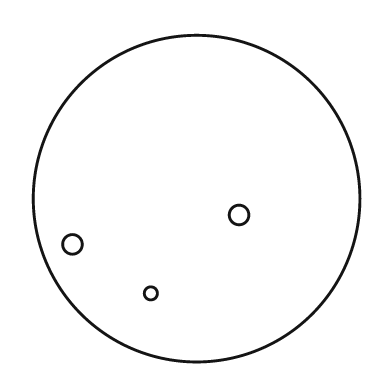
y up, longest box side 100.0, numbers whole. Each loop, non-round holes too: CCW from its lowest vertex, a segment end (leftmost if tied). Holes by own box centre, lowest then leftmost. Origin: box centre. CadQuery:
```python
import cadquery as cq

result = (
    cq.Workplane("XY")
    .moveTo(0.0, 0.0)
    .circle(50.0)
    .moveTo(-14.0, -29.0)
    .circle(2.0)
    .moveTo(-38.0, -14.0)
    .circle(3.0)
    .moveTo(13.0, -5.0)
    .circle(3.0)
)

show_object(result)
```